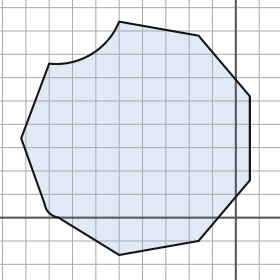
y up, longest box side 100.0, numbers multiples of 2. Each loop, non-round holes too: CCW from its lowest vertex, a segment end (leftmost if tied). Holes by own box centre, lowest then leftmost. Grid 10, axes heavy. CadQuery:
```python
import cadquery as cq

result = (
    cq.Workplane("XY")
    .moveTo(-50.0, -16.0)
    .lineTo(-16.0, -10.0)
    .lineTo(6.0, 16.0)
    .lineTo(6.0, 52.0)
    .lineTo(-16.0, 78.0)
    .lineTo(-50.0, 84.0)
    .threePointArc((-62.0, 70.0), (-80.0, 66.0))
    .lineTo(-92.0, 34.0)
    .lineTo(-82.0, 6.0)
    .threePointArc((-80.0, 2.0), (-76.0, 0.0))
    .close()
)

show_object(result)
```